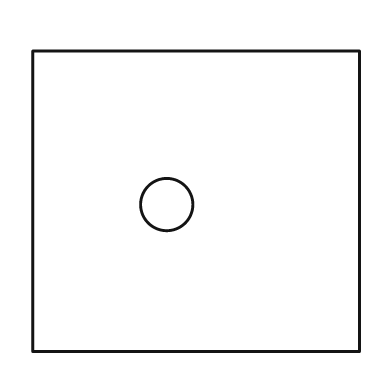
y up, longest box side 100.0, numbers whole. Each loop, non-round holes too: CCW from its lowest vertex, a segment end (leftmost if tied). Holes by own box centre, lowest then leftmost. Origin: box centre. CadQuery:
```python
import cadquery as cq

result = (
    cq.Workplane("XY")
    .moveTo(-50.0, -46.0)
    .lineTo(50.0, -46.0)
    .lineTo(50.0, 46.0)
    .lineTo(-50.0, 46.0)
    .close()
    .moveTo(-9.0, -1.0)
    .circle(8.0)
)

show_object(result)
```